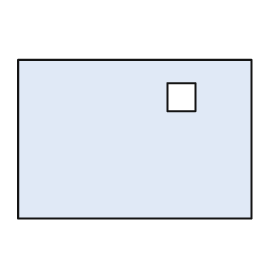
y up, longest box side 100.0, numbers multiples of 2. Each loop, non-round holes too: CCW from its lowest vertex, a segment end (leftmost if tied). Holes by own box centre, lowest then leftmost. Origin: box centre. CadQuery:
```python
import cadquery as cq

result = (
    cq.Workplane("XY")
    .moveTo(-50.0, -34.0)
    .lineTo(50.0, -34.0)
    .lineTo(50.0, 34.0)
    .lineTo(-50.0, 34.0)
    .close()
    .moveTo(14.0, 12.0)
    .lineTo(26.0, 12.0)
    .lineTo(26.0, 24.0)
    .lineTo(14.0, 24.0)
    .close()
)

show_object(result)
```